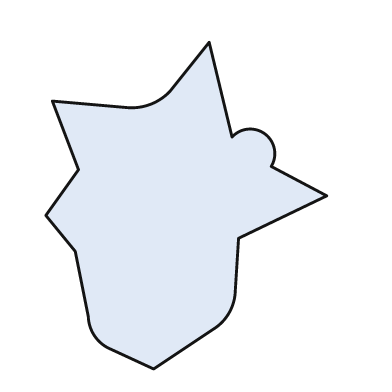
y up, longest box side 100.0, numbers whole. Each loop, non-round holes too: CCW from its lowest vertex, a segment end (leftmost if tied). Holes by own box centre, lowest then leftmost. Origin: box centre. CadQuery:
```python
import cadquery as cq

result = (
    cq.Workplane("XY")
    .moveTo(-10.0, -50.0)
    .lineTo(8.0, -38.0)
    .threePointArc((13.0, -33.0), (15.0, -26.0))
    .lineTo(16.0, -10.0)
    .lineTo(43.0, 3.0)
    .lineTo(26.0, 12.0)
    .threePointArc((24.0, 22.0), (14.0, 21.0))
    .lineTo(7.0, 50.0)
    .lineTo(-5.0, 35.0)
    .threePointArc((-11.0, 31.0), (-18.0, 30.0))
    .lineTo(-41.0, 32.0)
    .lineTo(-33.0, 11.0)
    .lineTo(-43.0, -3.0)
    .lineTo(-34.0, -14.0)
    .lineTo(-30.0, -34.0)
    .threePointArc((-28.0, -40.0), (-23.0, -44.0))
    .close()
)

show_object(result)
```